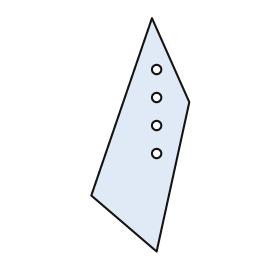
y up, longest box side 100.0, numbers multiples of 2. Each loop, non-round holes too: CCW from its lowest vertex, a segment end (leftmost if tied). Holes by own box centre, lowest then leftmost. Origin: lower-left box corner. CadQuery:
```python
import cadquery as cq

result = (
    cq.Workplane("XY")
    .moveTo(28.0, 0.0)
    .lineTo(42.0, 64.0)
    .lineTo(26.0, 100.0)
    .lineTo(0.0, 24.0)
    .close()
    .moveTo(28.0, 42.0)
    .circle(2.0)
    .moveTo(28.0, 54.0)
    .circle(2.0)
    .moveTo(28.0, 66.0)
    .circle(2.0)
    .moveTo(28.0, 78.0)
    .circle(2.0)
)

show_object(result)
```